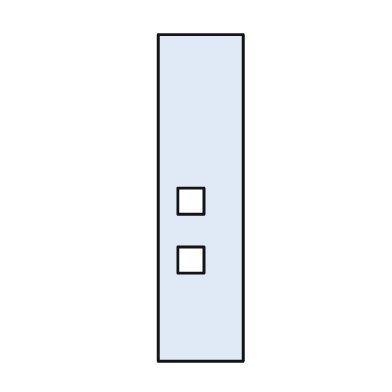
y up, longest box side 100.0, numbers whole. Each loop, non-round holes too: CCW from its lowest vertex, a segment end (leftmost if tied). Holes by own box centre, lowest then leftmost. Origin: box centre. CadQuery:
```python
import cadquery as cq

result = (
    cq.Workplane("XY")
    .moveTo(-13.0, -50.0)
    .lineTo(13.0, -50.0)
    .lineTo(13.0, 50.0)
    .lineTo(-13.0, 50.0)
    .close()
    .moveTo(-7.0, -23.0)
    .lineTo(1.0, -23.0)
    .lineTo(1.0, -15.0)
    .lineTo(-7.0, -15.0)
    .close()
    .moveTo(-7.0, -5.0)
    .lineTo(1.0, -5.0)
    .lineTo(1.0, 3.0)
    .lineTo(-7.0, 3.0)
    .close()
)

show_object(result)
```